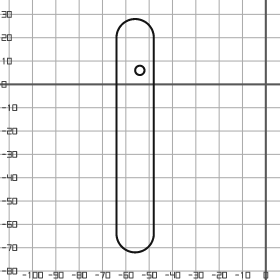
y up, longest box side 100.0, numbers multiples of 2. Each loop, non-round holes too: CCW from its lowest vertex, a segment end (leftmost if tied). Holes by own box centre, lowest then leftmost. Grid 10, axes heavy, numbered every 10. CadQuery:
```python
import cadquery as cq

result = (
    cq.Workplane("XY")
    .moveTo(-64.0, -64.0)
    .threePointArc((-56.0, -72.0), (-48.0, -64.0))
    .lineTo(-48.0, 20.0)
    .threePointArc((-56.0, 28.0), (-64.0, 20.0))
    .close()
    .moveTo(-54.0, 6.0)
    .circle(2.0)
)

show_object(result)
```